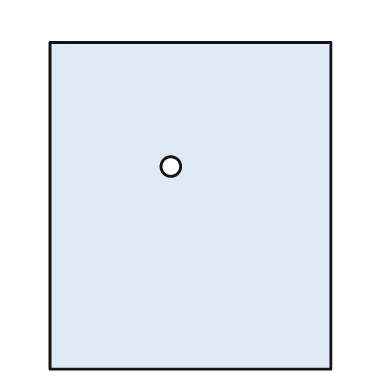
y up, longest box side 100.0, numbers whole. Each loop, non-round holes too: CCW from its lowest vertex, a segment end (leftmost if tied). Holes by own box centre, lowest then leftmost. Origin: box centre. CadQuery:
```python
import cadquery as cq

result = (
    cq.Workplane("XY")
    .moveTo(-43.0, -50.0)
    .lineTo(43.0, -50.0)
    .lineTo(43.0, 50.0)
    .lineTo(-43.0, 50.0)
    .close()
    .moveTo(-6.0, 12.0)
    .circle(3.0)
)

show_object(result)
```